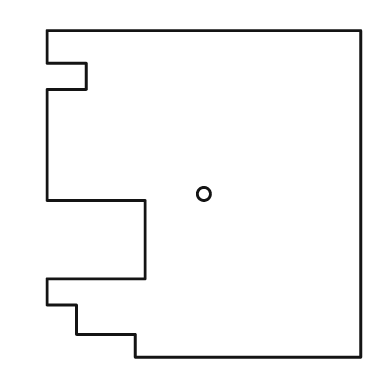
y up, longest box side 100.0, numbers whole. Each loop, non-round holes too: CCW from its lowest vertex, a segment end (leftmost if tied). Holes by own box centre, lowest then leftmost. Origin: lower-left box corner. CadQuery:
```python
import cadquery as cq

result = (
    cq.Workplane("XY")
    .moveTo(27.0, 0.0)
    .lineTo(96.0, 0.0)
    .lineTo(96.0, 100.0)
    .lineTo(0.0, 100.0)
    .lineTo(0.0, 90.0)
    .lineTo(12.0, 90.0)
    .lineTo(12.0, 82.0)
    .lineTo(0.0, 82.0)
    .lineTo(0.0, 48.0)
    .lineTo(30.0, 48.0)
    .lineTo(30.0, 24.0)
    .lineTo(0.0, 24.0)
    .lineTo(0.0, 16.0)
    .lineTo(9.0, 16.0)
    .lineTo(9.0, 7.0)
    .lineTo(27.0, 7.0)
    .close()
    .moveTo(48.0, 50.0)
    .circle(2.0)
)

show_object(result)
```